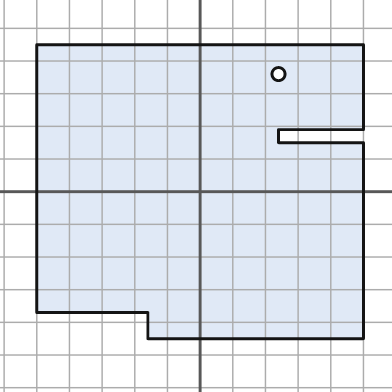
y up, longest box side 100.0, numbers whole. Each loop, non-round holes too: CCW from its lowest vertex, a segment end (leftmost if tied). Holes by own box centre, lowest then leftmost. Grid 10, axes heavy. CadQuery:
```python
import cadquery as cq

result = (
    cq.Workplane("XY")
    .moveTo(-16.0, -45.0)
    .lineTo(50.0, -45.0)
    .lineTo(50.0, 15.0)
    .lineTo(24.0, 15.0)
    .lineTo(24.0, 19.0)
    .lineTo(50.0, 19.0)
    .lineTo(50.0, 45.0)
    .lineTo(-50.0, 45.0)
    .lineTo(-50.0, -37.0)
    .lineTo(-16.0, -37.0)
    .close()
    .moveTo(24.0, 36.0)
    .circle(2.0)
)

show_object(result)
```